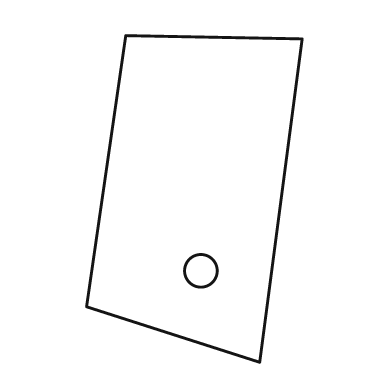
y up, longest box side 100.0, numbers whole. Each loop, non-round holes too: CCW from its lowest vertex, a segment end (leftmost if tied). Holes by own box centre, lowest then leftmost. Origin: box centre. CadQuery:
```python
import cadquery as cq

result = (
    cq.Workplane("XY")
    .moveTo(20.0, -50.0)
    .lineTo(33.0, 49.0)
    .lineTo(-21.0, 50.0)
    .lineTo(-33.0, -33.0)
    .close()
    .moveTo(2.0, -22.0)
    .circle(5.0)
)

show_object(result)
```